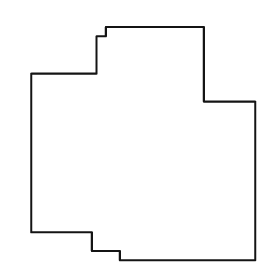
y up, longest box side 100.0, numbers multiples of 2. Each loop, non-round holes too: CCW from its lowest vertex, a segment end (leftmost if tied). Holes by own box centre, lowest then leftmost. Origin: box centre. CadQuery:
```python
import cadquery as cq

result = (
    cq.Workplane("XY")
    .moveTo(-10.0, -50.0)
    .lineTo(48.0, -50.0)
    .lineTo(48.0, 18.0)
    .lineTo(26.0, 18.0)
    .lineTo(26.0, 50.0)
    .lineTo(-16.0, 50.0)
    .lineTo(-16.0, 46.0)
    .lineTo(-20.0, 46.0)
    .lineTo(-20.0, 30.0)
    .lineTo(-48.0, 30.0)
    .lineTo(-48.0, -38.0)
    .lineTo(-22.0, -38.0)
    .lineTo(-22.0, -46.0)
    .lineTo(-10.0, -46.0)
    .close()
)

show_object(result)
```